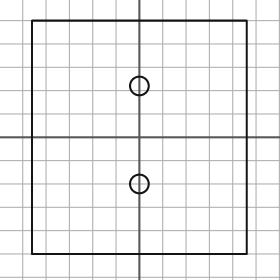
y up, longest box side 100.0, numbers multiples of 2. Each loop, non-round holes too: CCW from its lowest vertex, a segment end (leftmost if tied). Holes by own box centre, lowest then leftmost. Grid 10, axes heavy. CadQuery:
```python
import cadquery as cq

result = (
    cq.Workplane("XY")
    .moveTo(-46.0, -50.0)
    .lineTo(46.0, -50.0)
    .lineTo(46.0, 50.0)
    .lineTo(-46.0, 50.0)
    .close()
    .moveTo(0.0, -20.0)
    .circle(4.0)
    .moveTo(0.0, 22.0)
    .circle(4.0)
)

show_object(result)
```